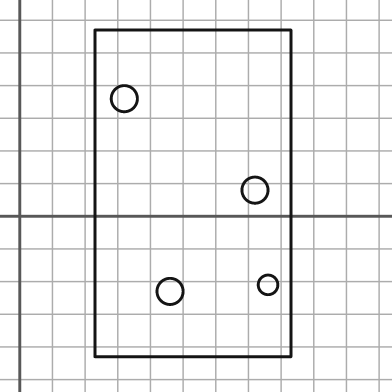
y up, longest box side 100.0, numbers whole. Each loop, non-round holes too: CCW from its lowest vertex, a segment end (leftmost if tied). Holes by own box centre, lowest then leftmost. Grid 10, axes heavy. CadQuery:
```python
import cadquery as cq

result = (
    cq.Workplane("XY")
    .moveTo(23.0, -43.0)
    .lineTo(83.0, -43.0)
    .lineTo(83.0, 57.0)
    .lineTo(23.0, 57.0)
    .close()
    .moveTo(46.0, -23.0)
    .circle(4.0)
    .moveTo(76.0, -21.0)
    .circle(3.0)
    .moveTo(72.0, 8.0)
    .circle(4.0)
    .moveTo(32.0, 36.0)
    .circle(4.0)
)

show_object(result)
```